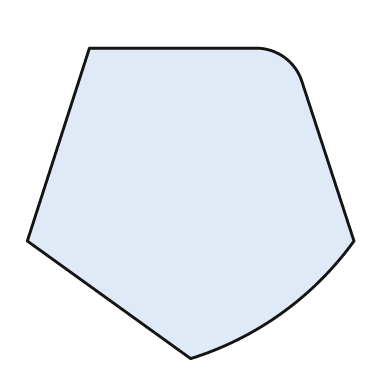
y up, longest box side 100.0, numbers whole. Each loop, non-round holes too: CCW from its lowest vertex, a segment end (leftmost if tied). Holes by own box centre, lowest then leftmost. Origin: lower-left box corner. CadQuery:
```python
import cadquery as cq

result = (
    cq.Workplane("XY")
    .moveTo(50.0, 0.0)
    .threePointArc((78.0, 14.0), (100.0, 36.0))
    .lineTo(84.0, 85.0)
    .threePointArc((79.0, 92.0), (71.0, 95.0))
    .lineTo(19.0, 95.0)
    .lineTo(0.0, 36.0)
    .close()
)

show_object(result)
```